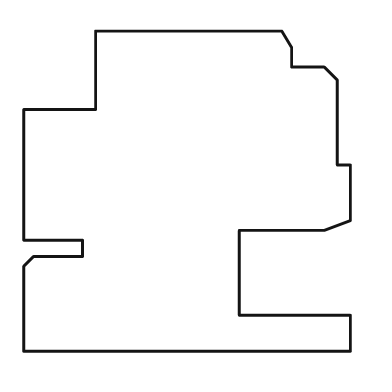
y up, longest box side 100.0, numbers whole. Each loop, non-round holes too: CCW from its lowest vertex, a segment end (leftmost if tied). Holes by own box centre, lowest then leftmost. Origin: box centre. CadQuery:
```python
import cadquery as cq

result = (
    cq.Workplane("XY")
    .moveTo(-50.0, -49.0)
    .lineTo(50.0, -49.0)
    .lineTo(50.0, -38.0)
    .lineTo(16.0, -38.0)
    .lineTo(16.0, -12.0)
    .lineTo(42.0, -12.0)
    .lineTo(50.0, -9.0)
    .lineTo(50.0, 8.0)
    .lineTo(46.0, 8.0)
    .lineTo(46.0, 34.0)
    .lineTo(42.0, 38.0)
    .lineTo(32.0, 38.0)
    .lineTo(32.0, 44.0)
    .lineTo(29.0, 49.0)
    .lineTo(-28.0, 49.0)
    .lineTo(-28.0, 25.0)
    .lineTo(-50.0, 25.0)
    .lineTo(-50.0, -15.0)
    .lineTo(-32.0, -15.0)
    .lineTo(-32.0, -20.0)
    .lineTo(-47.0, -20.0)
    .lineTo(-50.0, -23.0)
    .close()
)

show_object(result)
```